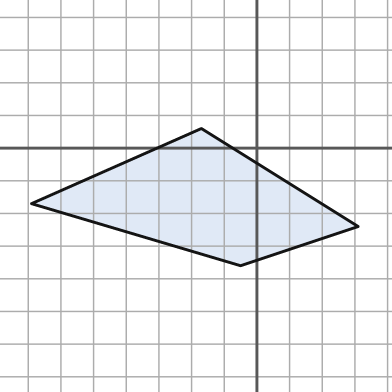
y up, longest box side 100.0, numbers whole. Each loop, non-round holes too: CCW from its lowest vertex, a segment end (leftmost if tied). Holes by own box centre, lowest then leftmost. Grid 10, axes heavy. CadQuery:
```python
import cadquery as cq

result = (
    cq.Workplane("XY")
    .moveTo(-5.0, -36.0)
    .lineTo(31.0, -24.0)
    .lineTo(-17.0, 6.0)
    .lineTo(-69.0, -17.0)
    .close()
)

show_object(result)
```